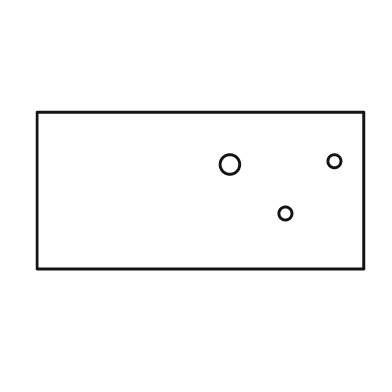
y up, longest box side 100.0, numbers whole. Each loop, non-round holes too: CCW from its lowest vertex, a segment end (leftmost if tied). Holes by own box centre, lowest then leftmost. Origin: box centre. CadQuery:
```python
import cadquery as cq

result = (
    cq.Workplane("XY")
    .moveTo(-50.0, -24.0)
    .lineTo(50.0, -24.0)
    .lineTo(50.0, 24.0)
    .lineTo(-50.0, 24.0)
    .close()
    .moveTo(26.0, -7.0)
    .circle(2.0)
    .moveTo(9.0, 8.0)
    .circle(3.0)
    .moveTo(41.0, 9.0)
    .circle(2.0)
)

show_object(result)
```